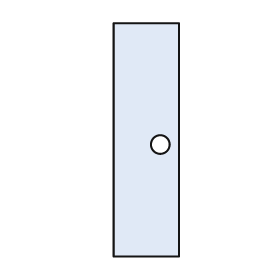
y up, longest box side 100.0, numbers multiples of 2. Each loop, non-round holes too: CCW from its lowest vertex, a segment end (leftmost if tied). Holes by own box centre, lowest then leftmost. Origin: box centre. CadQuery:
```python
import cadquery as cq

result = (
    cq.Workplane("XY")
    .moveTo(-14.0, -50.0)
    .lineTo(14.0, -50.0)
    .lineTo(14.0, 50.0)
    .lineTo(-14.0, 50.0)
    .close()
    .moveTo(6.0, -2.0)
    .circle(4.0)
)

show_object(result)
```